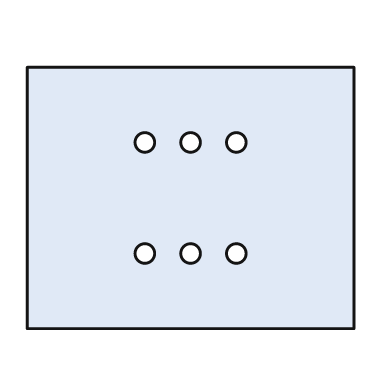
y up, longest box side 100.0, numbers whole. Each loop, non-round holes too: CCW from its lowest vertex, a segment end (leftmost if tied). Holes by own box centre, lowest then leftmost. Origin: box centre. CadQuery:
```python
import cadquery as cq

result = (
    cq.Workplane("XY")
    .moveTo(-50.0, -40.0)
    .lineTo(50.0, -40.0)
    .lineTo(50.0, 40.0)
    .lineTo(-50.0, 40.0)
    .close()
    .moveTo(-14.0, -17.0)
    .circle(3.0)
    .moveTo(0.0, -17.0)
    .circle(3.0)
    .moveTo(14.0, -17.0)
    .circle(3.0)
    .moveTo(-14.0, 17.0)
    .circle(3.0)
    .moveTo(0.0, 17.0)
    .circle(3.0)
    .moveTo(14.0, 17.0)
    .circle(3.0)
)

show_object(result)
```